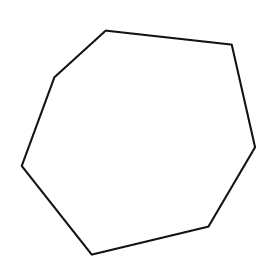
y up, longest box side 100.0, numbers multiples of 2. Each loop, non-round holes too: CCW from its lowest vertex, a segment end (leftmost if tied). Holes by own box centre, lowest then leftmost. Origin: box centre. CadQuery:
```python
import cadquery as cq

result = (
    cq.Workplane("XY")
    .moveTo(-20.0, -48.0)
    .lineTo(30.0, -36.0)
    .lineTo(50.0, -2.0)
    .lineTo(40.0, 42.0)
    .lineTo(-14.0, 48.0)
    .lineTo(-36.0, 28.0)
    .lineTo(-50.0, -10.0)
    .close()
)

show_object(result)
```